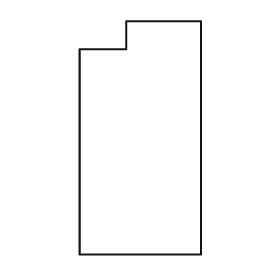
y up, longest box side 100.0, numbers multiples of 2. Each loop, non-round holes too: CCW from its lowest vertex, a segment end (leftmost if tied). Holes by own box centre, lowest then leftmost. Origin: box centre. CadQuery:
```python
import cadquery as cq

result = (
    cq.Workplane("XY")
    .moveTo(-26.0, -50.0)
    .lineTo(26.0, -50.0)
    .lineTo(26.0, 50.0)
    .lineTo(-6.0, 50.0)
    .lineTo(-6.0, 38.0)
    .lineTo(-26.0, 38.0)
    .close()
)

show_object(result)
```